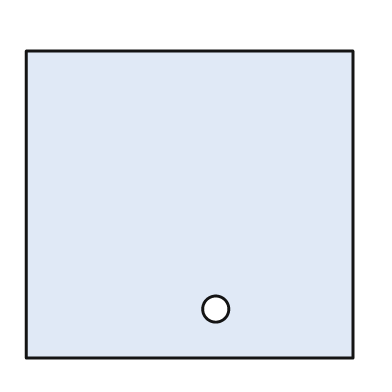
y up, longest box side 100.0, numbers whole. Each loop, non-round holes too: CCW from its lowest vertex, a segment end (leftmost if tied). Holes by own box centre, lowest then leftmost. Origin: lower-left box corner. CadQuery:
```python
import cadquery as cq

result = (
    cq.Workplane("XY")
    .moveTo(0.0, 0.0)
    .lineTo(100.0, 0.0)
    .lineTo(100.0, 94.0)
    .lineTo(0.0, 94.0)
    .close()
    .moveTo(58.0, 15.0)
    .circle(4.0)
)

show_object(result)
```